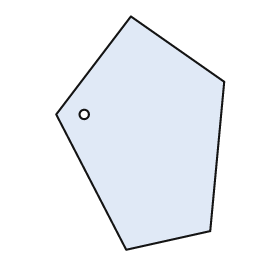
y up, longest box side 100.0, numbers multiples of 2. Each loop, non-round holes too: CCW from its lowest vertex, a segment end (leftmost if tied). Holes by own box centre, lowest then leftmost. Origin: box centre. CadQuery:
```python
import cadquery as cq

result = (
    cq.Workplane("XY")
    .moveTo(-6.0, -50.0)
    .lineTo(30.0, -42.0)
    .lineTo(36.0, 22.0)
    .lineTo(-4.0, 50.0)
    .lineTo(-36.0, 8.0)
    .close()
    .moveTo(-24.0, 8.0)
    .circle(2.0)
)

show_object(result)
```